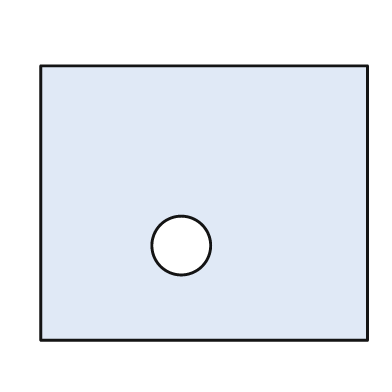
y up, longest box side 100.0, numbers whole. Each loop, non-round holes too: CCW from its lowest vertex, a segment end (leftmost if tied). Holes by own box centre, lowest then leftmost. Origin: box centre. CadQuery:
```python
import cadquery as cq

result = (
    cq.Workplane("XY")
    .moveTo(-50.0, -42.0)
    .lineTo(50.0, -42.0)
    .lineTo(50.0, 42.0)
    .lineTo(-50.0, 42.0)
    .close()
    .moveTo(-7.0, -13.0)
    .circle(9.0)
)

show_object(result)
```